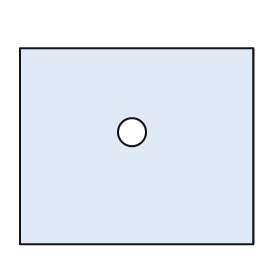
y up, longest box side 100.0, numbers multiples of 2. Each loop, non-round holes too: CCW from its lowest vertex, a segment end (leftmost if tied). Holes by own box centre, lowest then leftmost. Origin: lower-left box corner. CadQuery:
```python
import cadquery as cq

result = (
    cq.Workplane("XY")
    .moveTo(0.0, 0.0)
    .lineTo(100.0, 0.0)
    .lineTo(100.0, 84.0)
    .lineTo(0.0, 84.0)
    .close()
    .moveTo(48.0, 48.0)
    .circle(6.0)
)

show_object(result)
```